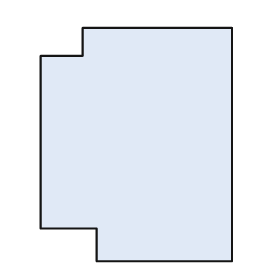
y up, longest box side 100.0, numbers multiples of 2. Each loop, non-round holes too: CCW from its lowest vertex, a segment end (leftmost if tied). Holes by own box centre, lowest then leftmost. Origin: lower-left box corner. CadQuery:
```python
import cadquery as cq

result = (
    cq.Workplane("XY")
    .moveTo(24.0, 0.0)
    .lineTo(82.0, 0.0)
    .lineTo(82.0, 100.0)
    .lineTo(18.0, 100.0)
    .lineTo(18.0, 88.0)
    .lineTo(0.0, 88.0)
    .lineTo(0.0, 14.0)
    .lineTo(24.0, 14.0)
    .close()
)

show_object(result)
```